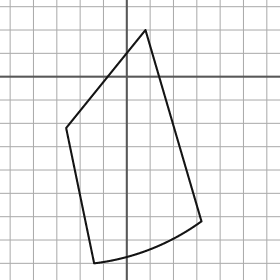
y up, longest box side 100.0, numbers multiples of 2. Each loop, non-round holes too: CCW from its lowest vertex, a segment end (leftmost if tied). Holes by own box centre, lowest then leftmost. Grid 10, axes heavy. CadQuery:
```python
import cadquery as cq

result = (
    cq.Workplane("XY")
    .moveTo(-14.0, -80.0)
    .threePointArc((10.0, -74.0), (32.0, -62.0))
    .lineTo(8.0, 20.0)
    .lineTo(-26.0, -22.0)
    .close()
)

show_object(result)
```